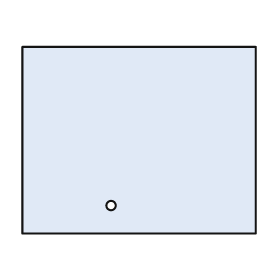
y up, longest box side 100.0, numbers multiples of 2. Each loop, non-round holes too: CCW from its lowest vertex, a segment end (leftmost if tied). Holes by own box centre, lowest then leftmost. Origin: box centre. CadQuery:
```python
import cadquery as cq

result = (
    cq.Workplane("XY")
    .moveTo(-50.0, -40.0)
    .lineTo(50.0, -40.0)
    .lineTo(50.0, 40.0)
    .lineTo(-50.0, 40.0)
    .close()
    .moveTo(-12.0, -28.0)
    .circle(2.0)
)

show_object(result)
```